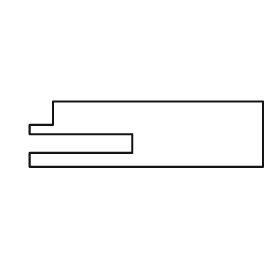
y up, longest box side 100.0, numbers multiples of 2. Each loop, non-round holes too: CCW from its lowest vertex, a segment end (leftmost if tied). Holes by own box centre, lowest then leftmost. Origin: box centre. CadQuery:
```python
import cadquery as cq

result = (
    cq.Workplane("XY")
    .moveTo(-50.0, -14.0)
    .lineTo(50.0, -14.0)
    .lineTo(50.0, 14.0)
    .lineTo(-40.0, 14.0)
    .lineTo(-40.0, 4.0)
    .lineTo(-50.0, 4.0)
    .lineTo(-50.0, 0.0)
    .lineTo(-6.0, 0.0)
    .lineTo(-6.0, -8.0)
    .lineTo(-50.0, -8.0)
    .close()
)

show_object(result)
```